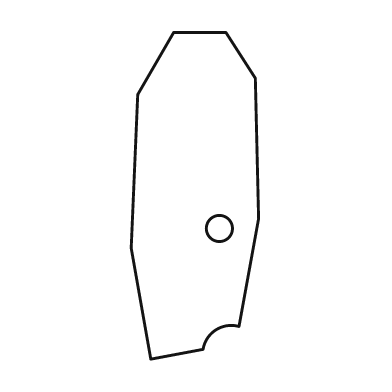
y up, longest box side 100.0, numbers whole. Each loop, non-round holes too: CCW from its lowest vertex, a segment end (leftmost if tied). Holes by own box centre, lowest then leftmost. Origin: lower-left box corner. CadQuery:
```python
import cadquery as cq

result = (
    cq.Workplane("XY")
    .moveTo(6.0, 0.0)
    .lineTo(22.0, 3.0)
    .threePointArc((26.0, 9.0), (33.0, 10.0))
    .lineTo(39.0, 43.0)
    .lineTo(38.0, 86.0)
    .lineTo(29.0, 100.0)
    .lineTo(13.0, 100.0)
    .lineTo(2.0, 81.0)
    .lineTo(0.0, 34.0)
    .close()
    .moveTo(27.0, 40.0)
    .circle(4.0)
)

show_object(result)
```